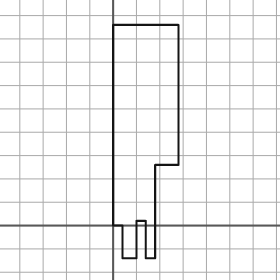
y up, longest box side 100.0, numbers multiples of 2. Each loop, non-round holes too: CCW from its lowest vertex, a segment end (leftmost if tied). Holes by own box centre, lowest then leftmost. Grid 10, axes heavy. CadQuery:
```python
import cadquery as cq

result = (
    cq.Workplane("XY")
    .moveTo(4.0, -14.0)
    .lineTo(10.0, -14.0)
    .lineTo(10.0, 2.0)
    .lineTo(14.0, 2.0)
    .lineTo(14.0, -14.0)
    .lineTo(18.0, -14.0)
    .lineTo(18.0, 26.0)
    .lineTo(28.0, 26.0)
    .lineTo(28.0, 86.0)
    .lineTo(0.0, 86.0)
    .lineTo(0.0, 0.0)
    .lineTo(4.0, 0.0)
    .close()
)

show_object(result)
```